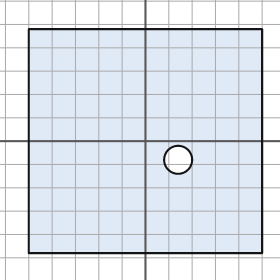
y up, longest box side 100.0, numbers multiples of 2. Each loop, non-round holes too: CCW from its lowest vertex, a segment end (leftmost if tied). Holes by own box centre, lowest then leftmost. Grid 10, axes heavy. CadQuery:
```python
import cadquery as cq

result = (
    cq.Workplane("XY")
    .moveTo(-50.0, -48.0)
    .lineTo(50.0, -48.0)
    .lineTo(50.0, 48.0)
    .lineTo(-50.0, 48.0)
    .close()
    .moveTo(14.0, -8.0)
    .circle(6.0)
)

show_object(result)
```